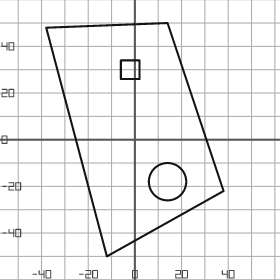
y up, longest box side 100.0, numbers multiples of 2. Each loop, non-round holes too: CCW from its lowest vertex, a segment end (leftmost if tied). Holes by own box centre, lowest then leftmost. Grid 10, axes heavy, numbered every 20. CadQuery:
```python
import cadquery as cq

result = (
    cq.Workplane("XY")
    .moveTo(-12.0, -50.0)
    .lineTo(38.0, -22.0)
    .lineTo(14.0, 50.0)
    .lineTo(-38.0, 48.0)
    .close()
    .moveTo(14.0, -18.0)
    .circle(8.0)
    .moveTo(-6.0, 26.0)
    .lineTo(2.0, 26.0)
    .lineTo(2.0, 34.0)
    .lineTo(-6.0, 34.0)
    .close()
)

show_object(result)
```